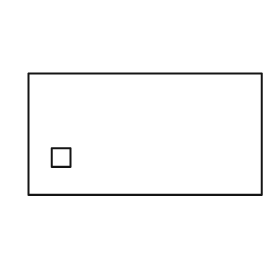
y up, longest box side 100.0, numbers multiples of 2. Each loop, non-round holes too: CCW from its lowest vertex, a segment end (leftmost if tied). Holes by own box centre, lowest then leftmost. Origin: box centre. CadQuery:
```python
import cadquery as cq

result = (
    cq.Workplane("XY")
    .moveTo(-50.0, -26.0)
    .lineTo(50.0, -26.0)
    .lineTo(50.0, 26.0)
    .lineTo(-50.0, 26.0)
    .close()
    .moveTo(-40.0, -14.0)
    .lineTo(-32.0, -14.0)
    .lineTo(-32.0, -6.0)
    .lineTo(-40.0, -6.0)
    .close()
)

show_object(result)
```